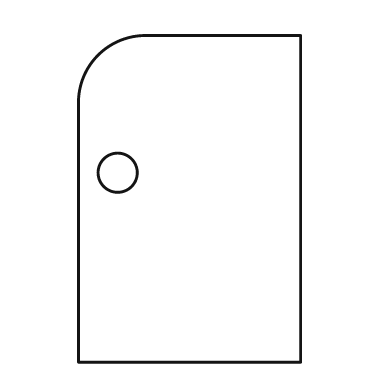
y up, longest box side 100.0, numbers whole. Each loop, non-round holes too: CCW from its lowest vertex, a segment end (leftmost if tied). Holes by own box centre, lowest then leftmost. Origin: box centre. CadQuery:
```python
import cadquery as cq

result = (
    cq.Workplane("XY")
    .moveTo(-34.0, -50.0)
    .lineTo(34.0, -50.0)
    .lineTo(34.0, 50.0)
    .lineTo(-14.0, 50.0)
    .threePointArc((-28.0, 44.0), (-34.0, 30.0))
    .close()
    .moveTo(-22.0, 8.0)
    .circle(6.0)
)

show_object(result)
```